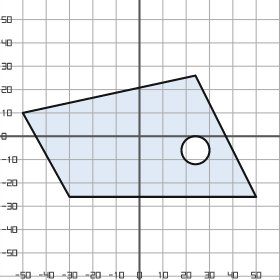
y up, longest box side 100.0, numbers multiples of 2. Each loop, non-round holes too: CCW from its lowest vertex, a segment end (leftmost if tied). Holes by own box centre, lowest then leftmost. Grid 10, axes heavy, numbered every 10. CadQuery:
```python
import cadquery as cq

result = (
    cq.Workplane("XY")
    .moveTo(-30.0, -26.0)
    .lineTo(50.0, -26.0)
    .lineTo(24.0, 26.0)
    .lineTo(-50.0, 10.0)
    .close()
    .moveTo(24.0, -6.0)
    .circle(6.0)
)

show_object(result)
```